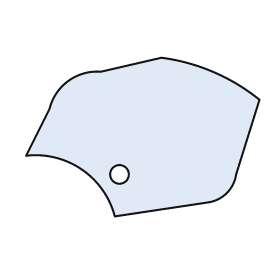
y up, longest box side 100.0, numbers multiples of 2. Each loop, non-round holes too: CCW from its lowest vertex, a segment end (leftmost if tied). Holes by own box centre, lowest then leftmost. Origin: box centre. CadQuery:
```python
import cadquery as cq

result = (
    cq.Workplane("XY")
    .moveTo(-12.0, -34.0)
    .lineTo(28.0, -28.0)
    .threePointArc((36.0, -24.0), (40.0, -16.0))
    .lineTo(50.0, 16.0)
    .threePointArc((30.0, 28.0), (8.0, 34.0))
    .lineTo(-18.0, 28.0)
    .threePointArc((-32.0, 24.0), (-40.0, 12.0))
    .lineTo(-50.0, -8.0)
    .threePointArc((-26.0, -14.0), (-12.0, -34.0))
    .close()
    .moveTo(-10.0, -16.0)
    .circle(4.0)
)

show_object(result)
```